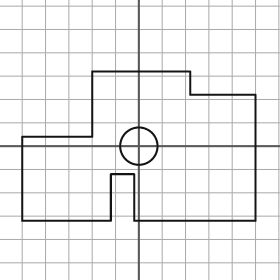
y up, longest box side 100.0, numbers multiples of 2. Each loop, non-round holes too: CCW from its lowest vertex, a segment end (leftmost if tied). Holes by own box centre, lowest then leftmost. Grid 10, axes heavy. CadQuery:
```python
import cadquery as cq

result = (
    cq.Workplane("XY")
    .moveTo(-50.0, -32.0)
    .lineTo(-12.0, -32.0)
    .lineTo(-12.0, -12.0)
    .lineTo(-2.0, -12.0)
    .lineTo(-2.0, -32.0)
    .lineTo(50.0, -32.0)
    .lineTo(50.0, 22.0)
    .lineTo(22.0, 22.0)
    .lineTo(22.0, 32.0)
    .lineTo(-20.0, 32.0)
    .lineTo(-20.0, 4.0)
    .lineTo(-50.0, 4.0)
    .close()
    .moveTo(0.0, 0.0)
    .circle(8.0)
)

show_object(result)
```